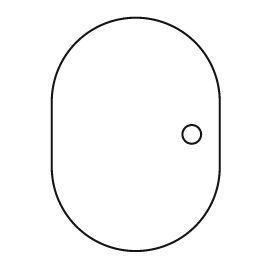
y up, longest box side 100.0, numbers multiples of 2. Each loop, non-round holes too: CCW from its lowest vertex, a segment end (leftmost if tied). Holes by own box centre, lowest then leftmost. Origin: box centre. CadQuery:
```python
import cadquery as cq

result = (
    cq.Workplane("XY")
    .moveTo(-36.0, -14.0)
    .threePointArc((0.0, -50.0), (36.0, -14.0))
    .lineTo(36.0, 14.0)
    .threePointArc((0.0, 50.0), (-36.0, 14.0))
    .close()
    .moveTo(24.0, 0.0)
    .circle(4.0)
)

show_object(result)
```